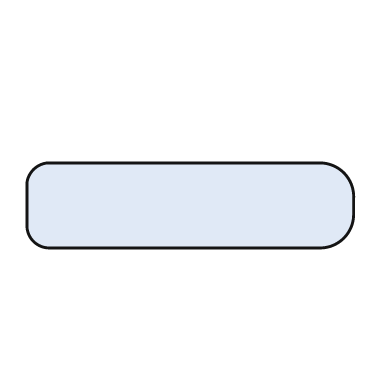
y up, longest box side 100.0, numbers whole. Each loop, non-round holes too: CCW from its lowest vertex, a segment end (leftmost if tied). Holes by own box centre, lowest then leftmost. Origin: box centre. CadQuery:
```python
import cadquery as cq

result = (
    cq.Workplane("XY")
    .moveTo(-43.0, -13.0)
    .lineTo(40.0, -13.0)
    .threePointArc((47.0, -10.0), (50.0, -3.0))
    .lineTo(50.0, 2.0)
    .threePointArc((47.0, 10.0), (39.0, 13.0))
    .lineTo(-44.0, 13.0)
    .threePointArc((-48.0, 11.0), (-50.0, 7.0))
    .lineTo(-50.0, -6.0)
    .threePointArc((-48.0, -11.0), (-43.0, -13.0))
    .close()
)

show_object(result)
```